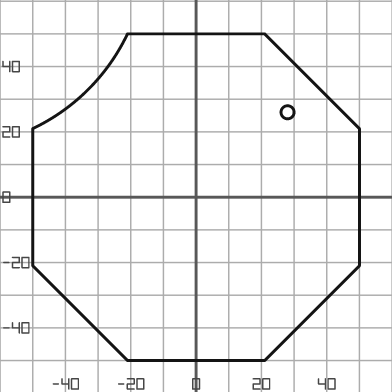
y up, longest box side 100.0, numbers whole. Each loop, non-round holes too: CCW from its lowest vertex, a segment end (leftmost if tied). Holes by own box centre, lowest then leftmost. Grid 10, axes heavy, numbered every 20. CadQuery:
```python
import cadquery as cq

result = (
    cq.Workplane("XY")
    .moveTo(-21.0, -50.0)
    .lineTo(21.0, -50.0)
    .lineTo(50.0, -21.0)
    .lineTo(50.0, 21.0)
    .lineTo(21.0, 50.0)
    .lineTo(-21.0, 50.0)
    .threePointArc((-33.0, 33.0), (-50.0, 21.0))
    .lineTo(-50.0, -21.0)
    .close()
    .moveTo(28.0, 26.0)
    .circle(2.0)
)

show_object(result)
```